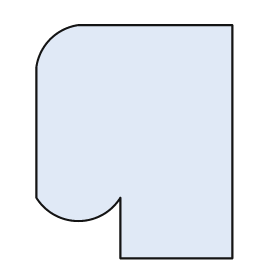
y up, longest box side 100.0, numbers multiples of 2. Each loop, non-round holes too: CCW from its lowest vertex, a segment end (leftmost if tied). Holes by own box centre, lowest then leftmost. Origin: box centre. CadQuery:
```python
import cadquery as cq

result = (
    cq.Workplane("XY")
    .moveTo(-6.0, -50.0)
    .lineTo(42.0, -50.0)
    .lineTo(42.0, 50.0)
    .lineTo(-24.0, 50.0)
    .threePointArc((-36.0, 44.0), (-42.0, 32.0))
    .lineTo(-42.0, -24.0)
    .threePointArc((-24.0, -34.0), (-6.0, -24.0))
    .close()
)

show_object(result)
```